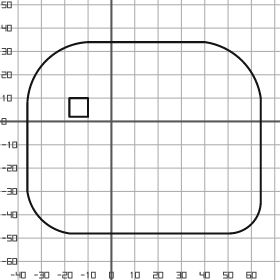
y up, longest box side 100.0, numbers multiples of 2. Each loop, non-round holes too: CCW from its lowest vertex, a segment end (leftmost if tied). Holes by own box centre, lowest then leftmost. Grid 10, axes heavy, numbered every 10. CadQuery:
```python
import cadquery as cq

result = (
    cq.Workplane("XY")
    .moveTo(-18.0, -48.0)
    .lineTo(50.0, -48.0)
    .threePointArc((60.0, -44.0), (64.0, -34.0))
    .lineTo(64.0, 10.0)
    .threePointArc((56.0, 26.0), (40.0, 34.0))
    .lineTo(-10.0, 34.0)
    .threePointArc((-28.0, 26.0), (-36.0, 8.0))
    .lineTo(-36.0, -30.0)
    .threePointArc((-30.0, -42.0), (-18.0, -48.0))
    .close()
    .moveTo(-18.0, 2.0)
    .lineTo(-10.0, 2.0)
    .lineTo(-10.0, 10.0)
    .lineTo(-18.0, 10.0)
    .close()
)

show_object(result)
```